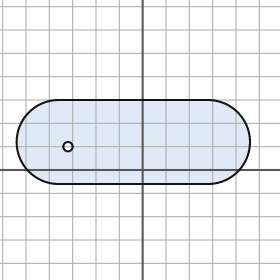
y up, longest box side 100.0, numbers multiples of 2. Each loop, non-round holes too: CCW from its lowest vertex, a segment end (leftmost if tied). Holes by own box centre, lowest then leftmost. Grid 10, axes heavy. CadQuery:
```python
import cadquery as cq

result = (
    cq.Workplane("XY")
    .moveTo(-36.0, -6.0)
    .lineTo(28.0, -6.0)
    .threePointArc((46.0, 12.0), (28.0, 30.0))
    .lineTo(-36.0, 30.0)
    .threePointArc((-54.0, 12.0), (-36.0, -6.0))
    .close()
    .moveTo(-32.0, 10.0)
    .circle(2.0)
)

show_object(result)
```